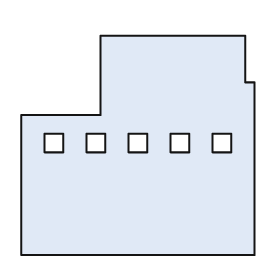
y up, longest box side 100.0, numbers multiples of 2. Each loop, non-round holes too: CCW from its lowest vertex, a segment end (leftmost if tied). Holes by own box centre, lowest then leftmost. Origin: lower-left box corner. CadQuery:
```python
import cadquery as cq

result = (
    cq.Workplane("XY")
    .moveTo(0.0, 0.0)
    .lineTo(100.0, 0.0)
    .lineTo(100.0, 74.0)
    .lineTo(96.0, 74.0)
    .lineTo(96.0, 94.0)
    .lineTo(34.0, 94.0)
    .lineTo(34.0, 60.0)
    .lineTo(0.0, 60.0)
    .close()
    .moveTo(10.0, 44.0)
    .lineTo(18.0, 44.0)
    .lineTo(18.0, 52.0)
    .lineTo(10.0, 52.0)
    .close()
    .moveTo(28.0, 44.0)
    .lineTo(36.0, 44.0)
    .lineTo(36.0, 52.0)
    .lineTo(28.0, 52.0)
    .close()
    .moveTo(46.0, 44.0)
    .lineTo(54.0, 44.0)
    .lineTo(54.0, 52.0)
    .lineTo(46.0, 52.0)
    .close()
    .moveTo(64.0, 44.0)
    .lineTo(72.0, 44.0)
    .lineTo(72.0, 52.0)
    .lineTo(64.0, 52.0)
    .close()
    .moveTo(82.0, 44.0)
    .lineTo(90.0, 44.0)
    .lineTo(90.0, 52.0)
    .lineTo(82.0, 52.0)
    .close()
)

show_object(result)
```